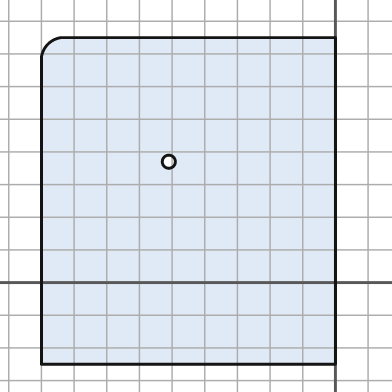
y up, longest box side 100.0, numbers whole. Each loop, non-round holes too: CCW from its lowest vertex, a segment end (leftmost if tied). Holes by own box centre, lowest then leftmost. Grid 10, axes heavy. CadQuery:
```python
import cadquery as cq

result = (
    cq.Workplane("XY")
    .moveTo(-90.0, -25.0)
    .lineTo(0.0, -25.0)
    .lineTo(0.0, 75.0)
    .lineTo(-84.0, 75.0)
    .threePointArc((-88.0, 73.0), (-90.0, 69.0))
    .close()
    .moveTo(-51.0, 37.0)
    .circle(2.0)
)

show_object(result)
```